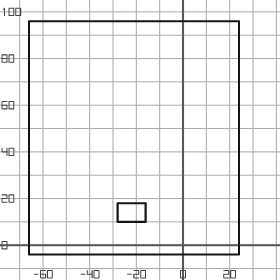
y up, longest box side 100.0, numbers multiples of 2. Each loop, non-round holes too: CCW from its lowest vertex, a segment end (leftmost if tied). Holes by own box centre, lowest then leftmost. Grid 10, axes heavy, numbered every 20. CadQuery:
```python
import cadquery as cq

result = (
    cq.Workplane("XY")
    .moveTo(-66.0, -4.0)
    .lineTo(24.0, -4.0)
    .lineTo(24.0, 96.0)
    .lineTo(-66.0, 96.0)
    .close()
    .moveTo(-28.0, 10.0)
    .lineTo(-16.0, 10.0)
    .lineTo(-16.0, 18.0)
    .lineTo(-28.0, 18.0)
    .close()
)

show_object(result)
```